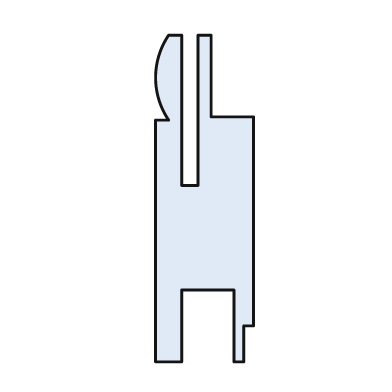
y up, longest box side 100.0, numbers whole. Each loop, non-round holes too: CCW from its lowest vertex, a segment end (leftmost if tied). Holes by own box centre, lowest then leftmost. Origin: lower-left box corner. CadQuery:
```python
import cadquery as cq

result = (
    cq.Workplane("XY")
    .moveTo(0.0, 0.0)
    .lineTo(8.0, 0.0)
    .lineTo(8.0, 22.0)
    .lineTo(24.0, 22.0)
    .lineTo(24.0, 0.0)
    .lineTo(27.0, 0.0)
    .lineTo(27.0, 11.0)
    .lineTo(30.0, 11.0)
    .lineTo(30.0, 75.0)
    .lineTo(17.0, 75.0)
    .lineTo(17.0, 100.0)
    .lineTo(13.0, 100.0)
    .lineTo(13.0, 54.0)
    .lineTo(8.0, 54.0)
    .lineTo(8.0, 100.0)
    .lineTo(4.0, 100.0)
    .threePointArc((0.0, 87.0), (4.0, 74.0))
    .lineTo(0.0, 74.0)
    .close()
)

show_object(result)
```